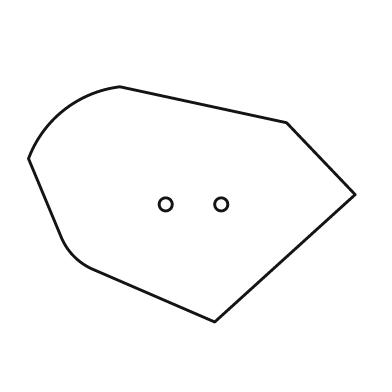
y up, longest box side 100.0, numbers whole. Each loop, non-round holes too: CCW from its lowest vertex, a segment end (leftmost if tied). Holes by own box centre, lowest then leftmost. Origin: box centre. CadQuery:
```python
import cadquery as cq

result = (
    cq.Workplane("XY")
    .moveTo(7.0, -36.0)
    .lineTo(50.0, 3.0)
    .lineTo(29.0, 25.0)
    .lineTo(-22.0, 36.0)
    .threePointArc((-39.0, 29.0), (-50.0, 14.0))
    .lineTo(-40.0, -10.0)
    .threePointArc((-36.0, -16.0), (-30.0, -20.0))
    .close()
    .moveTo(-8.0, 0.0)
    .circle(2.0)
    .moveTo(9.0, 0.0)
    .circle(2.0)
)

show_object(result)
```